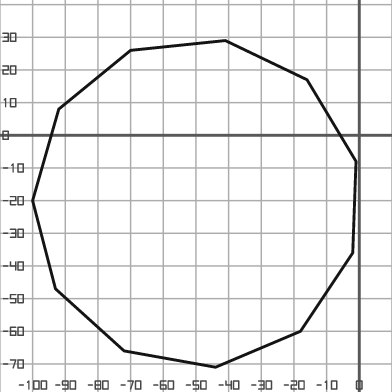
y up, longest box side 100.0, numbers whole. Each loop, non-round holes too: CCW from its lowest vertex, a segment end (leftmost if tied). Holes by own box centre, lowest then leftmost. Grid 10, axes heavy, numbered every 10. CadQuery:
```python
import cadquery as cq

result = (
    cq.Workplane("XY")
    .moveTo(-44.0, -71.0)
    .lineTo(-18.0, -60.0)
    .lineTo(-2.0, -36.0)
    .lineTo(-1.0, -8.0)
    .lineTo(-16.0, 17.0)
    .lineTo(-41.0, 29.0)
    .lineTo(-70.0, 26.0)
    .lineTo(-92.0, 8.0)
    .lineTo(-100.0, -20.0)
    .lineTo(-93.0, -47.0)
    .lineTo(-72.0, -66.0)
    .close()
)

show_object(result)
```